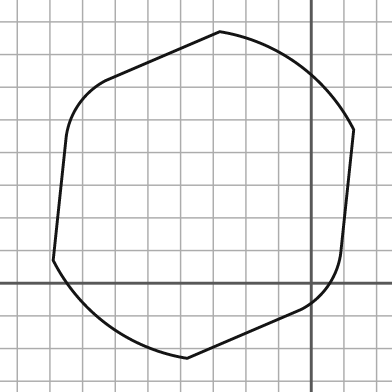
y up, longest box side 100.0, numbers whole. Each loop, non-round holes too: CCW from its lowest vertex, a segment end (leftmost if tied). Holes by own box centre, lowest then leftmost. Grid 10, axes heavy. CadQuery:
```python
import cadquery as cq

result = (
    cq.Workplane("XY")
    .moveTo(-38.0, -23.0)
    .lineTo(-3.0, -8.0)
    .threePointArc((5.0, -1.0), (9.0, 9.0))
    .lineTo(13.0, 47.0)
    .threePointArc((-4.0, 67.0), (-28.0, 77.0))
    .lineTo(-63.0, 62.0)
    .threePointArc((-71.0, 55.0), (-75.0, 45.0))
    .lineTo(-79.0, 7.0)
    .threePointArc((-62.0, -13.0), (-38.0, -23.0))
    .close()
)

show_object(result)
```